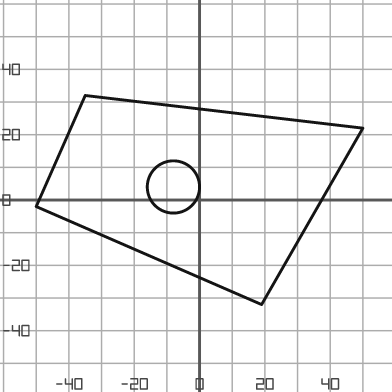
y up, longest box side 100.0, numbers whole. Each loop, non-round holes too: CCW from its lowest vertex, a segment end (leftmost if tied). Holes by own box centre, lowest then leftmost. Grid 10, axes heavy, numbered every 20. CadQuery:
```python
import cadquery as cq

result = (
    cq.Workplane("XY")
    .moveTo(19.0, -32.0)
    .lineTo(50.0, 22.0)
    .lineTo(-35.0, 32.0)
    .lineTo(-50.0, -2.0)
    .close()
    .moveTo(-8.0, 4.0)
    .circle(8.0)
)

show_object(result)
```